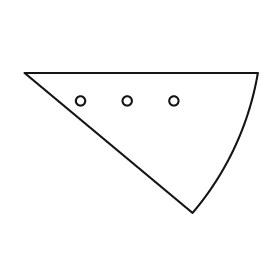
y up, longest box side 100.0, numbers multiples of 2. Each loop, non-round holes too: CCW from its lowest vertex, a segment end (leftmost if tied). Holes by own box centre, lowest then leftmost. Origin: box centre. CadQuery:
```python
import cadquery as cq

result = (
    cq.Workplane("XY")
    .moveTo(22.0, -30.0)
    .threePointArc((40.0, -2.0), (50.0, 30.0))
    .lineTo(-50.0, 30.0)
    .close()
    .moveTo(-26.0, 18.0)
    .circle(2.0)
    .moveTo(-6.0, 18.0)
    .circle(2.0)
    .moveTo(14.0, 18.0)
    .circle(2.0)
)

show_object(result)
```